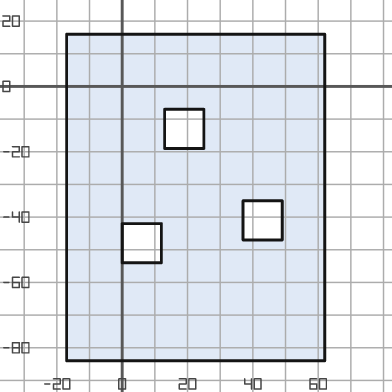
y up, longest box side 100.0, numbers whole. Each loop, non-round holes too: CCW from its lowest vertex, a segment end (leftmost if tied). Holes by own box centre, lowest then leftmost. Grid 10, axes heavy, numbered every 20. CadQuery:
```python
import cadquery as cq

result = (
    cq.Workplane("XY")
    .moveTo(-17.0, -84.0)
    .lineTo(62.0, -84.0)
    .lineTo(62.0, 16.0)
    .lineTo(-17.0, 16.0)
    .close()
    .moveTo(0.0, -54.0)
    .lineTo(12.0, -54.0)
    .lineTo(12.0, -42.0)
    .lineTo(0.0, -42.0)
    .close()
    .moveTo(37.0, -47.0)
    .lineTo(49.0, -47.0)
    .lineTo(49.0, -35.0)
    .lineTo(37.0, -35.0)
    .close()
    .moveTo(13.0, -19.0)
    .lineTo(25.0, -19.0)
    .lineTo(25.0, -7.0)
    .lineTo(13.0, -7.0)
    .close()
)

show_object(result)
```